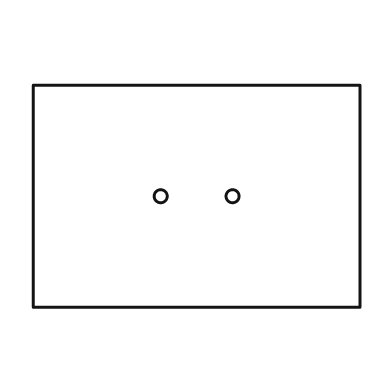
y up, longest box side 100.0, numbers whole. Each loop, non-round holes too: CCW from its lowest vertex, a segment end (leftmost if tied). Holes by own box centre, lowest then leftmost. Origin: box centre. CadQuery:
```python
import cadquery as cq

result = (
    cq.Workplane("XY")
    .moveTo(-50.0, -34.0)
    .lineTo(50.0, -34.0)
    .lineTo(50.0, 34.0)
    .lineTo(-50.0, 34.0)
    .close()
    .moveTo(-11.0, 0.0)
    .circle(2.0)
    .moveTo(11.0, 0.0)
    .circle(2.0)
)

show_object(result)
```